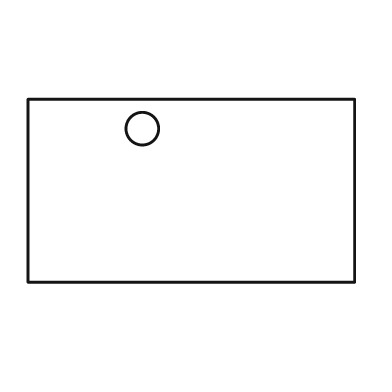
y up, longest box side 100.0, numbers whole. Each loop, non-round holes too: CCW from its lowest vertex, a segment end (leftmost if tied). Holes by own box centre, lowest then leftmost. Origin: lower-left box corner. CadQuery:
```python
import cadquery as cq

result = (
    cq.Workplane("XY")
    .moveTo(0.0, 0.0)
    .lineTo(100.0, 0.0)
    .lineTo(100.0, 56.0)
    .lineTo(0.0, 56.0)
    .close()
    .moveTo(35.0, 47.0)
    .circle(5.0)
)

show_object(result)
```